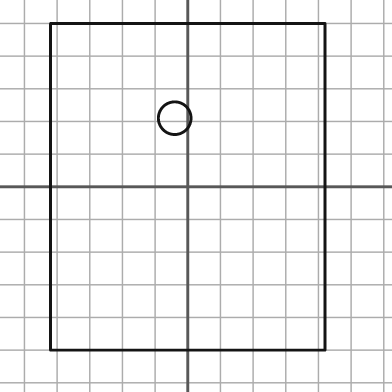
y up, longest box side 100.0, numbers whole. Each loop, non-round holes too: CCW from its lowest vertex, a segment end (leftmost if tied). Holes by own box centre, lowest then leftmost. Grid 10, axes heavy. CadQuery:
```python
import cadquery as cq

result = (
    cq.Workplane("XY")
    .moveTo(-42.0, -50.0)
    .lineTo(42.0, -50.0)
    .lineTo(42.0, 50.0)
    .lineTo(-42.0, 50.0)
    .close()
    .moveTo(-4.0, 21.0)
    .circle(5.0)
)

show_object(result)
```